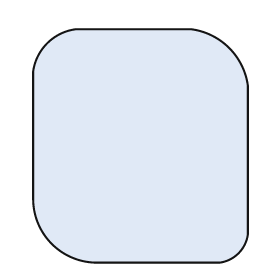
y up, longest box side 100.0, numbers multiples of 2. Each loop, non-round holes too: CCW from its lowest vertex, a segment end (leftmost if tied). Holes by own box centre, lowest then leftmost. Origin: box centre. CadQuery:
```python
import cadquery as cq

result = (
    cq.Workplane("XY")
    .moveTo(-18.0, -50.0)
    .lineTo(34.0, -50.0)
    .threePointArc((42.0, -46.0), (46.0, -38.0))
    .lineTo(46.0, 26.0)
    .threePointArc((38.0, 42.0), (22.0, 50.0))
    .lineTo(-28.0, 50.0)
    .threePointArc((-40.0, 44.0), (-46.0, 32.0))
    .lineTo(-46.0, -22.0)
    .threePointArc((-38.0, -42.0), (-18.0, -50.0))
    .close()
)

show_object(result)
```